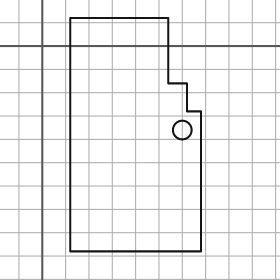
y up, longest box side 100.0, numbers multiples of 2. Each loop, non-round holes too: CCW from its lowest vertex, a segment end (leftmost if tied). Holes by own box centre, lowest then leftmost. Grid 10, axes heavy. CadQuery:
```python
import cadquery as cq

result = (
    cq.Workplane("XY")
    .moveTo(12.0, -88.0)
    .lineTo(68.0, -88.0)
    .lineTo(68.0, -28.0)
    .lineTo(62.0, -28.0)
    .lineTo(62.0, -16.0)
    .lineTo(54.0, -16.0)
    .lineTo(54.0, 12.0)
    .lineTo(12.0, 12.0)
    .close()
    .moveTo(60.0, -36.0)
    .circle(4.0)
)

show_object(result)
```